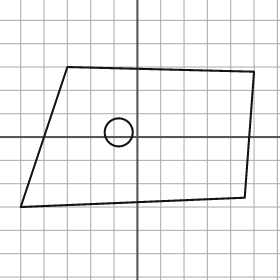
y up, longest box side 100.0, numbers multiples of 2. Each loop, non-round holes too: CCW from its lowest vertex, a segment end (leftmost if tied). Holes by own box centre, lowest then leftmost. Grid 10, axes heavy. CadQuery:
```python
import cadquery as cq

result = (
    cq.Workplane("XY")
    .moveTo(-50.0, -30.0)
    .lineTo(46.0, -26.0)
    .lineTo(50.0, 28.0)
    .lineTo(-30.0, 30.0)
    .close()
    .moveTo(-8.0, 2.0)
    .circle(6.0)
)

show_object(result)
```